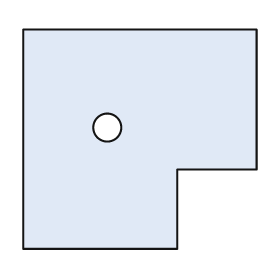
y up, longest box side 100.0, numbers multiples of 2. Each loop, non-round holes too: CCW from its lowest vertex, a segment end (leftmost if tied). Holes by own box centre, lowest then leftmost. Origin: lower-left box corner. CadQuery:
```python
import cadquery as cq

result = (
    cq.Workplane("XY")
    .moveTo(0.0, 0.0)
    .lineTo(66.0, 0.0)
    .lineTo(66.0, 34.0)
    .lineTo(100.0, 34.0)
    .lineTo(100.0, 94.0)
    .lineTo(0.0, 94.0)
    .close()
    .moveTo(36.0, 52.0)
    .circle(6.0)
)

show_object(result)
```